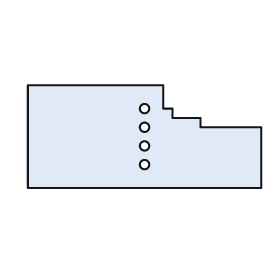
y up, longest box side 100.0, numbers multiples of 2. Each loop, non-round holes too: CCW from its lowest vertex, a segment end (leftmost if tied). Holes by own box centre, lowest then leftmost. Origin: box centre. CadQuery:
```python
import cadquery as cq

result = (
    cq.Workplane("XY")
    .moveTo(-50.0, -22.0)
    .lineTo(50.0, -22.0)
    .lineTo(50.0, 4.0)
    .lineTo(24.0, 4.0)
    .lineTo(24.0, 8.0)
    .lineTo(12.0, 8.0)
    .lineTo(12.0, 12.0)
    .lineTo(8.0, 12.0)
    .lineTo(8.0, 22.0)
    .lineTo(-50.0, 22.0)
    .close()
    .moveTo(0.0, -12.0)
    .circle(2.0)
    .moveTo(0.0, -4.0)
    .circle(2.0)
    .moveTo(0.0, 4.0)
    .circle(2.0)
    .moveTo(0.0, 12.0)
    .circle(2.0)
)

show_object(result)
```